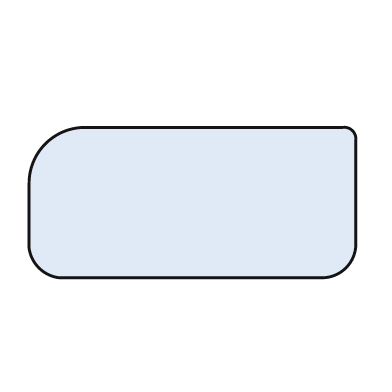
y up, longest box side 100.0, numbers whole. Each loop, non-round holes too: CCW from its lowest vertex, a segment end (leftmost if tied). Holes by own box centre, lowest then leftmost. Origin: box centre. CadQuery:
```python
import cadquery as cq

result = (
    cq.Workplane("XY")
    .moveTo(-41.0, -23.0)
    .lineTo(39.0, -23.0)
    .threePointArc((47.0, -20.0), (50.0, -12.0))
    .lineTo(50.0, 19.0)
    .threePointArc((49.0, 22.0), (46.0, 23.0))
    .lineTo(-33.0, 23.0)
    .threePointArc((-45.0, 18.0), (-50.0, 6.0))
    .lineTo(-50.0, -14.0)
    .threePointArc((-47.0, -20.0), (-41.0, -23.0))
    .close()
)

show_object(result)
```